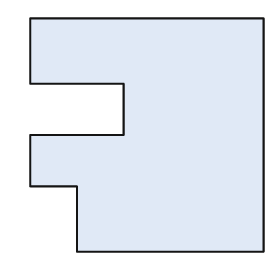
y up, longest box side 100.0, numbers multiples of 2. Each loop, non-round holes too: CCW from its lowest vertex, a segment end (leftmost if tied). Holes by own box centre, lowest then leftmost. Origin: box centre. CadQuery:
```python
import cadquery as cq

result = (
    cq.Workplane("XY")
    .moveTo(-30.0, -50.0)
    .lineTo(50.0, -50.0)
    .lineTo(50.0, 50.0)
    .lineTo(-50.0, 50.0)
    .lineTo(-50.0, 22.0)
    .lineTo(-10.0, 22.0)
    .lineTo(-10.0, 0.0)
    .lineTo(-50.0, 0.0)
    .lineTo(-50.0, -22.0)
    .lineTo(-30.0, -22.0)
    .close()
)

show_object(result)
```